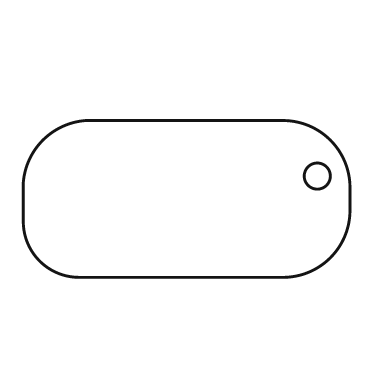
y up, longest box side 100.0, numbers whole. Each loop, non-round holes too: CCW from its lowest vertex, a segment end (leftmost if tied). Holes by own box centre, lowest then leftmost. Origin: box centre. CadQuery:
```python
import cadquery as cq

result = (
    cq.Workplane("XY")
    .moveTo(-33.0, -24.0)
    .lineTo(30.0, -24.0)
    .threePointArc((44.0, -18.0), (50.0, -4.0))
    .lineTo(50.0, 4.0)
    .threePointArc((44.0, 18.0), (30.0, 24.0))
    .lineTo(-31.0, 24.0)
    .threePointArc((-44.0, 18.0), (-50.0, 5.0))
    .lineTo(-50.0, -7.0)
    .threePointArc((-45.0, -19.0), (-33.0, -24.0))
    .close()
    .moveTo(40.0, 7.0)
    .circle(4.0)
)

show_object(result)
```